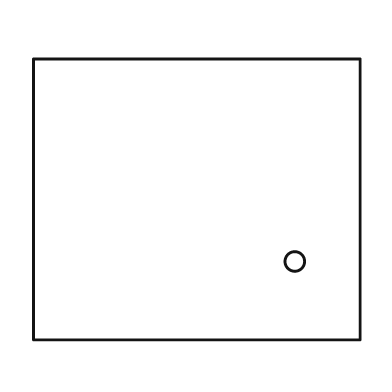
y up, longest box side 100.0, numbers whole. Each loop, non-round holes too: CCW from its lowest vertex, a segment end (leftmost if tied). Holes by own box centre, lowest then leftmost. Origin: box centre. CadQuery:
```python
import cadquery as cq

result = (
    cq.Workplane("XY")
    .moveTo(-50.0, -43.0)
    .lineTo(50.0, -43.0)
    .lineTo(50.0, 43.0)
    .lineTo(-50.0, 43.0)
    .close()
    .moveTo(30.0, -19.0)
    .circle(3.0)
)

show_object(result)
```